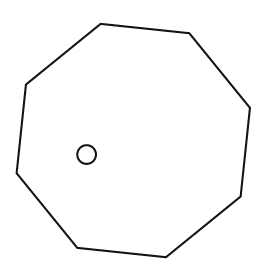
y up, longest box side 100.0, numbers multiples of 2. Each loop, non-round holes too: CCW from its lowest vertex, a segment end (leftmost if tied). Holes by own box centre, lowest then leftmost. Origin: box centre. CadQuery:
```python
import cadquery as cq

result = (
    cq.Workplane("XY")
    .moveTo(14.0, -50.0)
    .lineTo(46.0, -24.0)
    .lineTo(50.0, 14.0)
    .lineTo(24.0, 46.0)
    .lineTo(-14.0, 50.0)
    .lineTo(-46.0, 24.0)
    .lineTo(-50.0, -14.0)
    .lineTo(-24.0, -46.0)
    .close()
    .moveTo(-20.0, -6.0)
    .circle(4.0)
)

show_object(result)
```